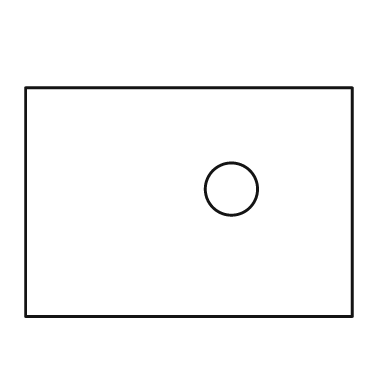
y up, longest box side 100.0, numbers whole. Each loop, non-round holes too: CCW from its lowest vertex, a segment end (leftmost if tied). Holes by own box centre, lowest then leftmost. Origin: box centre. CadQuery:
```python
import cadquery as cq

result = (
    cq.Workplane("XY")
    .moveTo(-50.0, -35.0)
    .lineTo(50.0, -35.0)
    .lineTo(50.0, 35.0)
    .lineTo(-50.0, 35.0)
    .close()
    .moveTo(13.0, 4.0)
    .circle(8.0)
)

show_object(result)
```